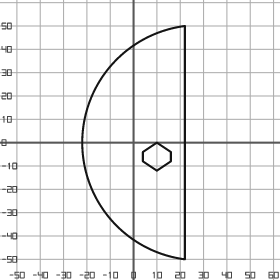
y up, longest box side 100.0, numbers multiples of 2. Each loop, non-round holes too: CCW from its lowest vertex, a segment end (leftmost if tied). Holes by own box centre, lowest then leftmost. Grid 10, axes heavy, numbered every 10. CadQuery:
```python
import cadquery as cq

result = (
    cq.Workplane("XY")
    .moveTo(22.0, -50.0)
    .lineTo(22.0, 50.0)
    .threePointArc((-22.0, 0.0), (22.0, -50.0))
    .close()
    .moveTo(10.0, -12.0)
    .lineTo(16.0, -8.0)
    .lineTo(16.0, -4.0)
    .lineTo(10.0, 0.0)
    .lineTo(4.0, -4.0)
    .lineTo(4.0, -8.0)
    .close()
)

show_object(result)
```